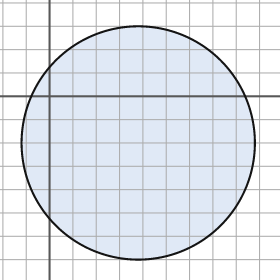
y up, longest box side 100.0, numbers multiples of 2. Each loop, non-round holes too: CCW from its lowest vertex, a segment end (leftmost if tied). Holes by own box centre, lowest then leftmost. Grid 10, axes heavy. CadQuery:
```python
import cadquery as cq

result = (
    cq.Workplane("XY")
    .moveTo(38.0, -20.0)
    .circle(50.0)
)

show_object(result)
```